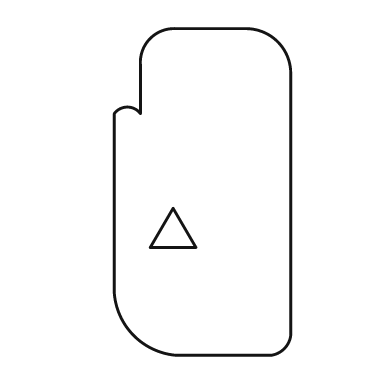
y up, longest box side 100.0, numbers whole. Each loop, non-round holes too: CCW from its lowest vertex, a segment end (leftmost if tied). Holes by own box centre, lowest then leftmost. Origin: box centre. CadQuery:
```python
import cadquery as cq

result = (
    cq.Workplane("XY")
    .moveTo(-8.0, -50.0)
    .lineTo(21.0, -50.0)
    .threePointArc((25.0, -48.0), (27.0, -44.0))
    .lineTo(27.0, 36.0)
    .threePointArc((23.0, 46.0), (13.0, 50.0))
    .lineTo(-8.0, 50.0)
    .threePointArc((-16.0, 47.0), (-19.0, 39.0))
    .lineTo(-19.0, 24.0)
    .threePointArc((-23.0, 26.0), (-27.0, 24.0))
    .lineTo(-27.0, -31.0)
    .threePointArc((-21.0, -44.0), (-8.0, -50.0))
    .close()
    .moveTo(-16.0, -17.0)
    .lineTo(-2.0, -17.0)
    .lineTo(-9.0, -5.0)
    .close()
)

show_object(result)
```